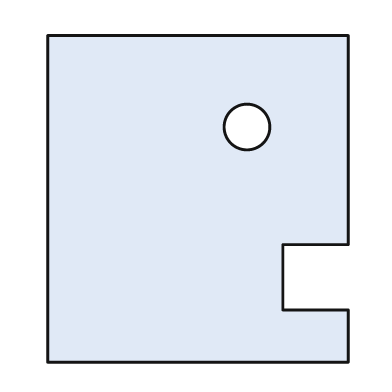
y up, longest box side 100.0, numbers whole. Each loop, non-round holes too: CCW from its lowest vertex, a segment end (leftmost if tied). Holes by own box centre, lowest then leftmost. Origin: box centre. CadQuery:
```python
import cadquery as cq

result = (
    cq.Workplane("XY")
    .moveTo(-46.0, -50.0)
    .lineTo(46.0, -50.0)
    .lineTo(46.0, -34.0)
    .lineTo(26.0, -34.0)
    .lineTo(26.0, -14.0)
    .lineTo(46.0, -14.0)
    .lineTo(46.0, 50.0)
    .lineTo(-46.0, 50.0)
    .close()
    .moveTo(15.0, 22.0)
    .circle(7.0)
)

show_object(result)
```